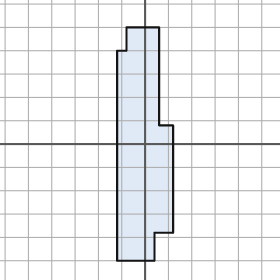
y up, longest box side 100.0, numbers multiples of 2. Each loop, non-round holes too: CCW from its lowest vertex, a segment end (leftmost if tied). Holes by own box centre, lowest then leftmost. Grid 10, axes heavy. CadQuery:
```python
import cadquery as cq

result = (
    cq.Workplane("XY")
    .moveTo(-12.0, -50.0)
    .lineTo(4.0, -50.0)
    .lineTo(4.0, -38.0)
    .lineTo(12.0, -38.0)
    .lineTo(12.0, 8.0)
    .lineTo(6.0, 8.0)
    .lineTo(6.0, 50.0)
    .lineTo(-8.0, 50.0)
    .lineTo(-8.0, 40.0)
    .lineTo(-12.0, 40.0)
    .close()
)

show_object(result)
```